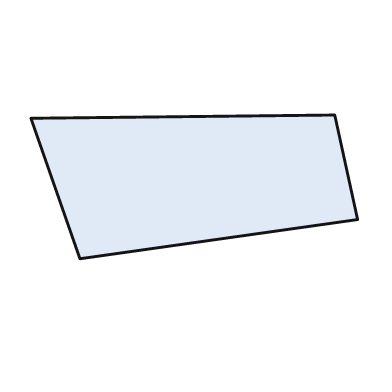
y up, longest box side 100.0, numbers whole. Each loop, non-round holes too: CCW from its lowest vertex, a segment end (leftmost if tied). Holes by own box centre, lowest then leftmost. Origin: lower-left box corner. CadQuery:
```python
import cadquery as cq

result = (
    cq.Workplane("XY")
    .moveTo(15.0, 0.0)
    .lineTo(100.0, 12.0)
    .lineTo(93.0, 44.0)
    .lineTo(0.0, 43.0)
    .close()
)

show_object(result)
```